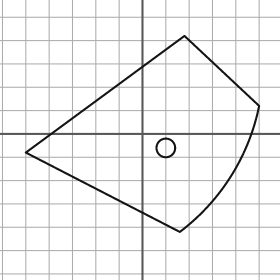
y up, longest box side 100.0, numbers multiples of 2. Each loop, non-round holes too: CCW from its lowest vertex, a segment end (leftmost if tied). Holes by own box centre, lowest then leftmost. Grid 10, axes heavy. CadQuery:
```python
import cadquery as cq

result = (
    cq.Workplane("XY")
    .moveTo(16.0, -42.0)
    .threePointArc((38.0, -18.0), (50.0, 12.0))
    .lineTo(18.0, 42.0)
    .lineTo(-50.0, -8.0)
    .close()
    .moveTo(10.0, -6.0)
    .circle(4.0)
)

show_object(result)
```